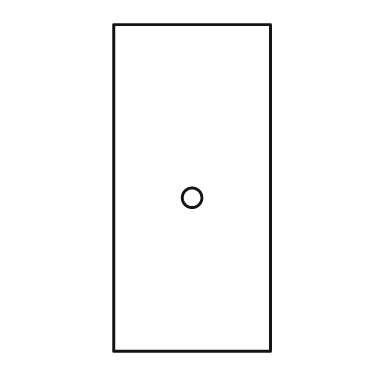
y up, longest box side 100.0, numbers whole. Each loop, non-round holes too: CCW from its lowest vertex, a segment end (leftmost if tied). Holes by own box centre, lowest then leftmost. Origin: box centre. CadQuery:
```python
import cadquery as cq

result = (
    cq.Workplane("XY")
    .moveTo(-24.0, -50.0)
    .lineTo(24.0, -50.0)
    .lineTo(24.0, 50.0)
    .lineTo(-24.0, 50.0)
    .close()
    .moveTo(0.0, -3.0)
    .circle(3.0)
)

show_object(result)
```